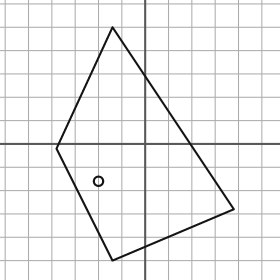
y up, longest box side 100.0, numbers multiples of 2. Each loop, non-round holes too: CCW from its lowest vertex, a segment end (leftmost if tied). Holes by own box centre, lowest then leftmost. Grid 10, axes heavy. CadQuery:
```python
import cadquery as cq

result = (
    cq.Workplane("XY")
    .moveTo(-14.0, -50.0)
    .lineTo(38.0, -28.0)
    .lineTo(-14.0, 50.0)
    .lineTo(-38.0, -2.0)
    .close()
    .moveTo(-20.0, -16.0)
    .circle(2.0)
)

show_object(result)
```